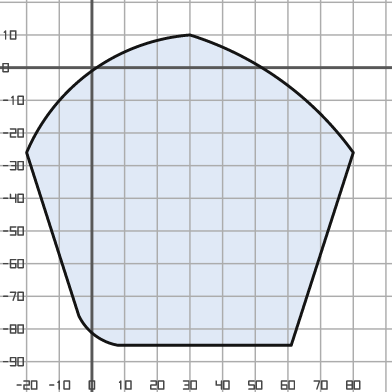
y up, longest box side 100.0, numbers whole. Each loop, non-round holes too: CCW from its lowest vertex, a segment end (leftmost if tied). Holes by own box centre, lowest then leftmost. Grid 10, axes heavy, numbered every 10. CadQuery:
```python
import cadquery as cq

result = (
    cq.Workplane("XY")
    .moveTo(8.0, -85.0)
    .lineTo(61.0, -85.0)
    .lineTo(80.0, -26.0)
    .threePointArc((58.0, -4.0), (30.0, 10.0))
    .threePointArc((0.0, -1.0), (-20.0, -26.0))
    .lineTo(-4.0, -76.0)
    .threePointArc((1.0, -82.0), (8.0, -85.0))
    .close()
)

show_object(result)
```